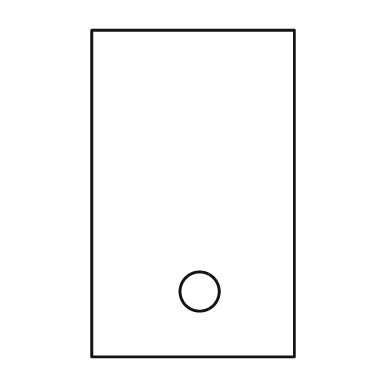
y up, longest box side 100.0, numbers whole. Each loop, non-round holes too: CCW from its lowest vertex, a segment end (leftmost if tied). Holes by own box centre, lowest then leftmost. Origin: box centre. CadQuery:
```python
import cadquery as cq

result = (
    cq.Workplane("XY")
    .moveTo(-31.0, -50.0)
    .lineTo(31.0, -50.0)
    .lineTo(31.0, 50.0)
    .lineTo(-31.0, 50.0)
    .close()
    .moveTo(2.0, -30.0)
    .circle(6.0)
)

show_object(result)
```